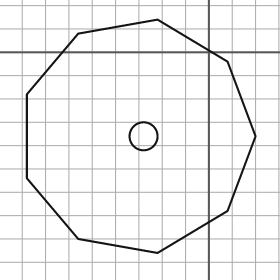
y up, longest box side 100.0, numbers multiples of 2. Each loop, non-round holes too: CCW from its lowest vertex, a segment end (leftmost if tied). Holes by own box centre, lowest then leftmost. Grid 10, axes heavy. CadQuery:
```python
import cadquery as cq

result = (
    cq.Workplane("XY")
    .moveTo(-22.0, -86.0)
    .lineTo(8.0, -68.0)
    .lineTo(20.0, -36.0)
    .lineTo(8.0, -4.0)
    .lineTo(-22.0, 14.0)
    .lineTo(-56.0, 8.0)
    .lineTo(-78.0, -18.0)
    .lineTo(-78.0, -54.0)
    .lineTo(-56.0, -80.0)
    .close()
    .moveTo(-28.0, -36.0)
    .circle(6.0)
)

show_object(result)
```